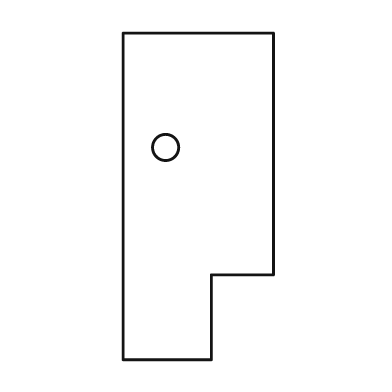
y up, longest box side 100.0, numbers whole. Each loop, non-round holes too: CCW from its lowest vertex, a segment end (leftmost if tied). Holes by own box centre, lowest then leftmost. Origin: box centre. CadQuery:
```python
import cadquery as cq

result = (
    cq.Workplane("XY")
    .moveTo(-23.0, -50.0)
    .lineTo(4.0, -50.0)
    .lineTo(4.0, -24.0)
    .lineTo(23.0, -24.0)
    .lineTo(23.0, 50.0)
    .lineTo(-23.0, 50.0)
    .close()
    .moveTo(-10.0, 15.0)
    .circle(4.0)
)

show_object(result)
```